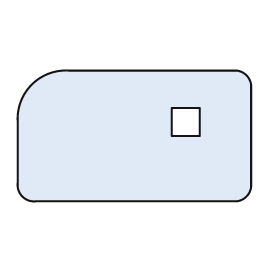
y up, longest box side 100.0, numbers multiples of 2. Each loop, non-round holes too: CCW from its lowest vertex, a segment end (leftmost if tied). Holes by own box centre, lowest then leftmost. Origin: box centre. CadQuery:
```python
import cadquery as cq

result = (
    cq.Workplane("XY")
    .moveTo(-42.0, -28.0)
    .lineTo(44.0, -28.0)
    .threePointArc((48.0, -26.0), (50.0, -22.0))
    .lineTo(50.0, 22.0)
    .threePointArc((48.0, 26.0), (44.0, 28.0))
    .lineTo(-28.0, 28.0)
    .threePointArc((-44.0, 22.0), (-50.0, 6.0))
    .lineTo(-50.0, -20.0)
    .threePointArc((-48.0, -26.0), (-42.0, -28.0))
    .close()
    .moveTo(16.0, 0.0)
    .lineTo(28.0, 0.0)
    .lineTo(28.0, 12.0)
    .lineTo(16.0, 12.0)
    .close()
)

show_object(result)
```